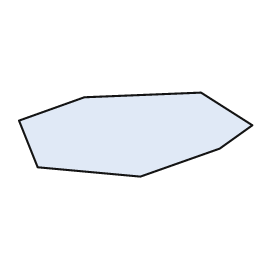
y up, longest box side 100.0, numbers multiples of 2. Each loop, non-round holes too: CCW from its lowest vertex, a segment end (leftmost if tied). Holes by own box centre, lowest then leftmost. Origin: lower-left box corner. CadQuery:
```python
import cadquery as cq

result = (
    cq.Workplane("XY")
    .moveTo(52.0, 0.0)
    .lineTo(86.0, 12.0)
    .lineTo(100.0, 22.0)
    .lineTo(78.0, 36.0)
    .lineTo(28.0, 34.0)
    .lineTo(0.0, 24.0)
    .lineTo(8.0, 4.0)
    .close()
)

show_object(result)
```